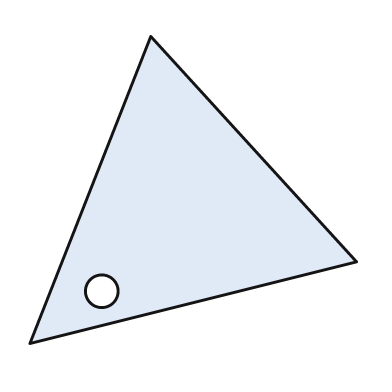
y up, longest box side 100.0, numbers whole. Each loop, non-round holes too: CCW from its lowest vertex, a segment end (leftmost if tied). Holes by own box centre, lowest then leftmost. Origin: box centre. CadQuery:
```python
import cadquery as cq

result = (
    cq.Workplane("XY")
    .moveTo(-50.0, -47.0)
    .lineTo(50.0, -22.0)
    .lineTo(-13.0, 47.0)
    .close()
    .moveTo(-28.0, -31.0)
    .circle(5.0)
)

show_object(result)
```